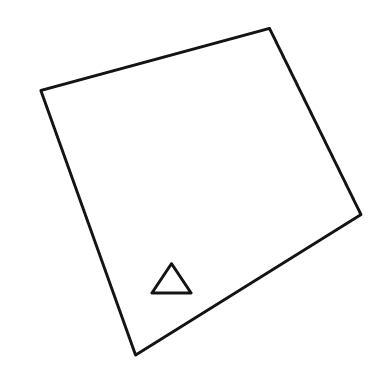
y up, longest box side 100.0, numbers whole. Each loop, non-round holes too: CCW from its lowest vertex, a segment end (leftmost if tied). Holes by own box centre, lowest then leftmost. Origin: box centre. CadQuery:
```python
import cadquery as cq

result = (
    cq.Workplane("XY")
    .moveTo(-20.0, -50.0)
    .lineTo(49.0, -7.0)
    .lineTo(21.0, 50.0)
    .lineTo(-49.0, 31.0)
    .close()
    .moveTo(-15.0, -31.0)
    .lineTo(-3.0, -31.0)
    .lineTo(-9.0, -22.0)
    .close()
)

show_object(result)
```